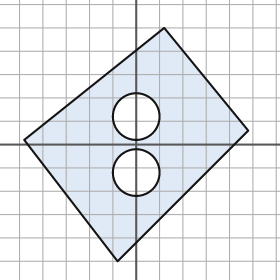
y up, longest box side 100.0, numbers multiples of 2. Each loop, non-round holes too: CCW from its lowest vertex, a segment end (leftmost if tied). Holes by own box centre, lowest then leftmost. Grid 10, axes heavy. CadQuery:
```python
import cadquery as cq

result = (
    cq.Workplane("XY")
    .moveTo(-8.0, -50.0)
    .lineTo(48.0, 6.0)
    .lineTo(12.0, 50.0)
    .lineTo(-48.0, 2.0)
    .close()
    .moveTo(0.0, -12.0)
    .circle(10.0)
    .moveTo(0.0, 12.0)
    .circle(10.0)
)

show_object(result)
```